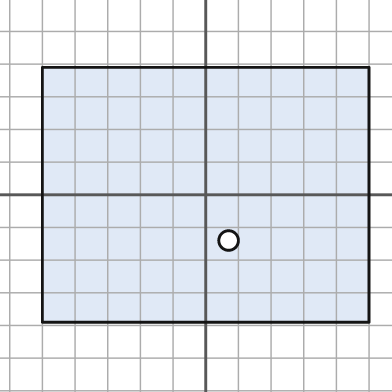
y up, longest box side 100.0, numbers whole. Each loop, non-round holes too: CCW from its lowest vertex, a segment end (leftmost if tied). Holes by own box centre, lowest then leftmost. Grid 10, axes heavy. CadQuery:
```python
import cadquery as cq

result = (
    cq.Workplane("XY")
    .moveTo(-50.0, -39.0)
    .lineTo(50.0, -39.0)
    .lineTo(50.0, 39.0)
    .lineTo(-50.0, 39.0)
    .close()
    .moveTo(7.0, -14.0)
    .circle(3.0)
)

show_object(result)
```